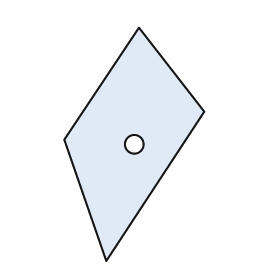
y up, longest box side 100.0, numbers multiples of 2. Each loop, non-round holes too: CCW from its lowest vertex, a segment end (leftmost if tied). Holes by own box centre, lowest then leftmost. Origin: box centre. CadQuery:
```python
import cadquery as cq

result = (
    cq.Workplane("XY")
    .moveTo(-12.0, -50.0)
    .lineTo(30.0, 14.0)
    .lineTo(2.0, 50.0)
    .lineTo(-30.0, 2.0)
    .close()
    .moveTo(0.0, 0.0)
    .circle(4.0)
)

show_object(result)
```